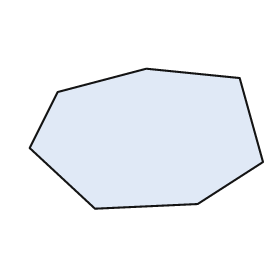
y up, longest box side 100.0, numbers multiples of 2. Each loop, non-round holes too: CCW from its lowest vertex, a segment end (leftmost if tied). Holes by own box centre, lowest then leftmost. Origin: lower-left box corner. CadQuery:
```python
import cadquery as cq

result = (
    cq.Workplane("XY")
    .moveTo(28.0, 0.0)
    .lineTo(72.0, 2.0)
    .lineTo(100.0, 20.0)
    .lineTo(90.0, 56.0)
    .lineTo(50.0, 60.0)
    .lineTo(12.0, 50.0)
    .lineTo(0.0, 26.0)
    .close()
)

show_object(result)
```